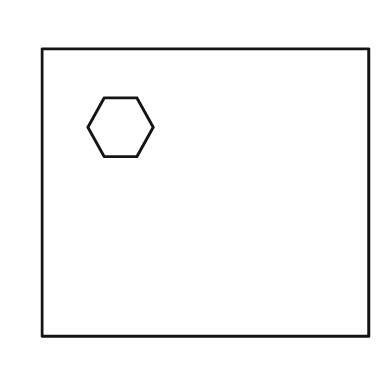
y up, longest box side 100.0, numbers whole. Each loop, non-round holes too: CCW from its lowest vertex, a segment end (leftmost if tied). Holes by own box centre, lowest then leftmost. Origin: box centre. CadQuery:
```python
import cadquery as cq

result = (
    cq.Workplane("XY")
    .moveTo(-50.0, -44.0)
    .lineTo(50.0, -44.0)
    .lineTo(50.0, 44.0)
    .lineTo(-50.0, 44.0)
    .close()
    .moveTo(-31.0, 11.0)
    .lineTo(-21.0, 11.0)
    .lineTo(-16.0, 20.0)
    .lineTo(-21.0, 29.0)
    .lineTo(-31.0, 29.0)
    .lineTo(-36.0, 20.0)
    .close()
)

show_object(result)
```